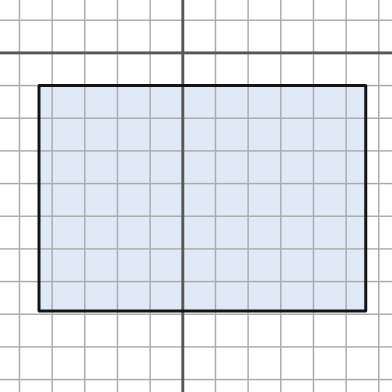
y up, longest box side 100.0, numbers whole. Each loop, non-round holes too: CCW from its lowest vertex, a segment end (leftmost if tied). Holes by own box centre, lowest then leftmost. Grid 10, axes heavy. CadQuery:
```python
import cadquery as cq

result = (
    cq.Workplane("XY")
    .moveTo(-44.0, -79.0)
    .lineTo(56.0, -79.0)
    .lineTo(56.0, -10.0)
    .lineTo(-44.0, -10.0)
    .close()
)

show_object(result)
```